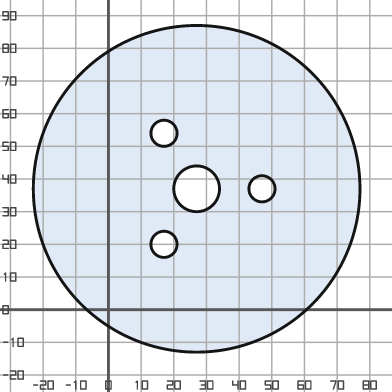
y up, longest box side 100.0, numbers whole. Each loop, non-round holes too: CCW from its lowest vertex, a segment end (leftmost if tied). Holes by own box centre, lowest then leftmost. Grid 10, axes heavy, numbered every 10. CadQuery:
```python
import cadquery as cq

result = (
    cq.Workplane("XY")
    .moveTo(27.0, 37.0)
    .circle(50.0)
    .moveTo(17.0, 20.0)
    .circle(4.0)
    .moveTo(27.0, 37.0)
    .circle(7.0)
    .moveTo(47.0, 37.0)
    .circle(4.0)
    .moveTo(17.0, 54.0)
    .circle(4.0)
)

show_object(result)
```